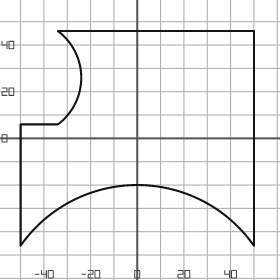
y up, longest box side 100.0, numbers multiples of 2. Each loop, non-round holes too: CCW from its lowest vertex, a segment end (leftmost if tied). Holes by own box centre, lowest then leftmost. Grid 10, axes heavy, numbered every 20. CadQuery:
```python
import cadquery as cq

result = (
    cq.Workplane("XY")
    .moveTo(-50.0, -46.0)
    .threePointArc((0.0, -20.0), (50.0, -46.0))
    .lineTo(50.0, 46.0)
    .lineTo(-34.0, 46.0)
    .threePointArc((-24.0, 26.0), (-34.0, 6.0))
    .lineTo(-50.0, 6.0)
    .close()
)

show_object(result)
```